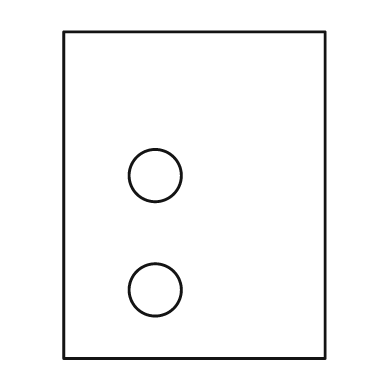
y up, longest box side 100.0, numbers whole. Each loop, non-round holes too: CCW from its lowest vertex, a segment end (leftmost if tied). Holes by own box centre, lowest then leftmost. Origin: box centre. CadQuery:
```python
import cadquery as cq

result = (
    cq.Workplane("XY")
    .moveTo(-40.0, -50.0)
    .lineTo(40.0, -50.0)
    .lineTo(40.0, 50.0)
    .lineTo(-40.0, 50.0)
    .close()
    .moveTo(-12.0, -29.0)
    .circle(8.0)
    .moveTo(-12.0, 6.0)
    .circle(8.0)
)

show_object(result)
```